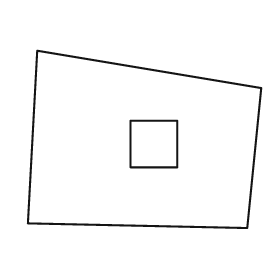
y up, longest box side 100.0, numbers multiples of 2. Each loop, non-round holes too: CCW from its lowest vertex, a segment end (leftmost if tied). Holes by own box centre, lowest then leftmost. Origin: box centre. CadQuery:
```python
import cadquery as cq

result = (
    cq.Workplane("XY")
    .moveTo(44.0, -38.0)
    .lineTo(50.0, 22.0)
    .lineTo(-46.0, 38.0)
    .lineTo(-50.0, -36.0)
    .close()
    .moveTo(-6.0, -12.0)
    .lineTo(14.0, -12.0)
    .lineTo(14.0, 8.0)
    .lineTo(-6.0, 8.0)
    .close()
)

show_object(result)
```